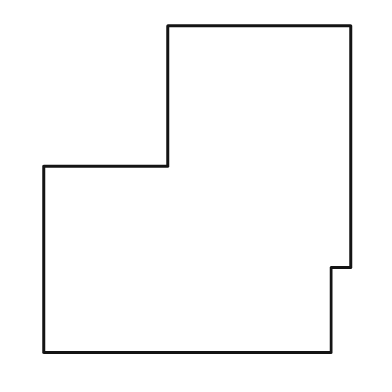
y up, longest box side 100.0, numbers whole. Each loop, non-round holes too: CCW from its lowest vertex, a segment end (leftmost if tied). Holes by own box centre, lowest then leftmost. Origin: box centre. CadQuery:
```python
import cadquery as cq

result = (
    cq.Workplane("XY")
    .moveTo(-47.0, -50.0)
    .lineTo(41.0, -50.0)
    .lineTo(41.0, -24.0)
    .lineTo(47.0, -24.0)
    .lineTo(47.0, 50.0)
    .lineTo(-9.0, 50.0)
    .lineTo(-9.0, 7.0)
    .lineTo(-47.0, 7.0)
    .close()
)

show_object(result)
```